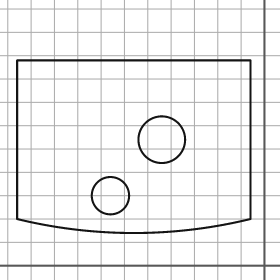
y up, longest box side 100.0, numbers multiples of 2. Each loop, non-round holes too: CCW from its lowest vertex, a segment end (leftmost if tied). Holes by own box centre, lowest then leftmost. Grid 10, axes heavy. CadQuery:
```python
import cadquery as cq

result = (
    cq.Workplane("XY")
    .moveTo(-106.0, 20.0)
    .threePointArc((-56.0, 14.0), (-6.0, 20.0))
    .lineTo(-6.0, 88.0)
    .lineTo(-106.0, 88.0)
    .close()
    .moveTo(-66.0, 30.0)
    .circle(8.0)
    .moveTo(-44.0, 54.0)
    .circle(10.0)
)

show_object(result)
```